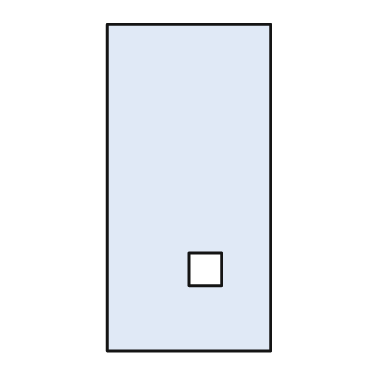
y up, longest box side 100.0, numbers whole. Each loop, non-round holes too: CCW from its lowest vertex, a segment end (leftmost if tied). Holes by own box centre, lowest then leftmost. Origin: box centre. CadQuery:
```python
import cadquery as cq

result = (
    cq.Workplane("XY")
    .moveTo(-25.0, -50.0)
    .lineTo(25.0, -50.0)
    .lineTo(25.0, 50.0)
    .lineTo(-25.0, 50.0)
    .close()
    .moveTo(0.0, -30.0)
    .lineTo(10.0, -30.0)
    .lineTo(10.0, -20.0)
    .lineTo(0.0, -20.0)
    .close()
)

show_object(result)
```